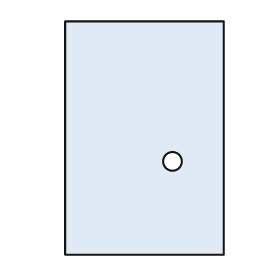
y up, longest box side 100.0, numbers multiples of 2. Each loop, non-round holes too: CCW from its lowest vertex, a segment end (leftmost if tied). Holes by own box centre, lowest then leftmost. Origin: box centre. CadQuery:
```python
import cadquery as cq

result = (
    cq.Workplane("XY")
    .moveTo(-34.0, -50.0)
    .lineTo(34.0, -50.0)
    .lineTo(34.0, 50.0)
    .lineTo(-34.0, 50.0)
    .close()
    .moveTo(12.0, -10.0)
    .circle(4.0)
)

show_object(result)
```